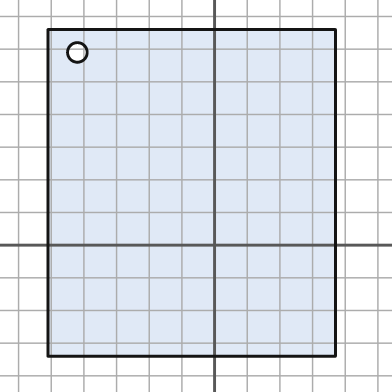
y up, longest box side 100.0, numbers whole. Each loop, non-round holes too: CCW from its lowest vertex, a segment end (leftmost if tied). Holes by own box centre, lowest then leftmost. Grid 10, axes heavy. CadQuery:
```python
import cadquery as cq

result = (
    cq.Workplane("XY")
    .moveTo(-51.0, -34.0)
    .lineTo(37.0, -34.0)
    .lineTo(37.0, 66.0)
    .lineTo(-51.0, 66.0)
    .close()
    .moveTo(-42.0, 59.0)
    .circle(3.0)
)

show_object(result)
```